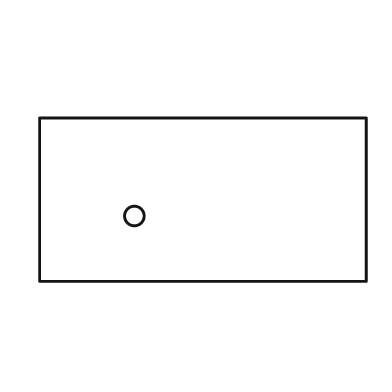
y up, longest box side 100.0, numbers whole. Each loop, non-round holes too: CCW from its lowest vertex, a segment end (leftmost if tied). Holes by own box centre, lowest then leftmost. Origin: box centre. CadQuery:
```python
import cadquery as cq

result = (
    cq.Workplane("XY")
    .moveTo(-50.0, -25.0)
    .lineTo(50.0, -25.0)
    .lineTo(50.0, 25.0)
    .lineTo(-50.0, 25.0)
    .close()
    .moveTo(-21.0, -5.0)
    .circle(3.0)
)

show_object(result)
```